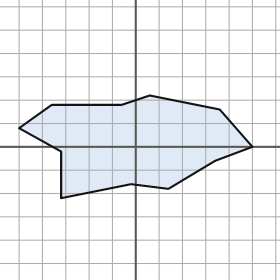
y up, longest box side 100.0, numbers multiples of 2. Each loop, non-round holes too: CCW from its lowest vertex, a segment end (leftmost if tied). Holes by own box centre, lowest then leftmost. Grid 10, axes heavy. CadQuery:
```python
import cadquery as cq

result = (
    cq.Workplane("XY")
    .moveTo(-32.0, -22.0)
    .lineTo(-2.0, -16.0)
    .lineTo(14.0, -18.0)
    .lineTo(34.0, -6.0)
    .lineTo(50.0, 0.0)
    .lineTo(36.0, 16.0)
    .lineTo(6.0, 22.0)
    .lineTo(-6.0, 18.0)
    .lineTo(-36.0, 18.0)
    .lineTo(-50.0, 8.0)
    .lineTo(-32.0, -2.0)
    .close()
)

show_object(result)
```